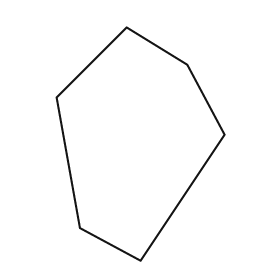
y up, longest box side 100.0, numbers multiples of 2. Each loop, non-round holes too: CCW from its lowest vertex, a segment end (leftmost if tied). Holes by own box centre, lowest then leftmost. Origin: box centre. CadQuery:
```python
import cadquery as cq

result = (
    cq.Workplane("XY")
    .moveTo(0.0, -50.0)
    .lineTo(36.0, 4.0)
    .lineTo(20.0, 34.0)
    .lineTo(-6.0, 50.0)
    .lineTo(-36.0, 20.0)
    .lineTo(-26.0, -36.0)
    .close()
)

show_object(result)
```